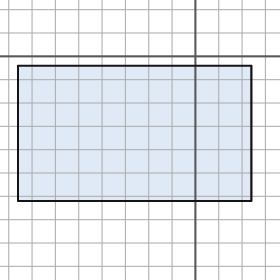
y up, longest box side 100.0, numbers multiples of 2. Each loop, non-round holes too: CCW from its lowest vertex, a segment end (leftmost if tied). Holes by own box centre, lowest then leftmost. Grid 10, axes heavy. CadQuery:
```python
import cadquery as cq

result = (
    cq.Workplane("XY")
    .moveTo(-76.0, -62.0)
    .lineTo(24.0, -62.0)
    .lineTo(24.0, -4.0)
    .lineTo(-76.0, -4.0)
    .close()
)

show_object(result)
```